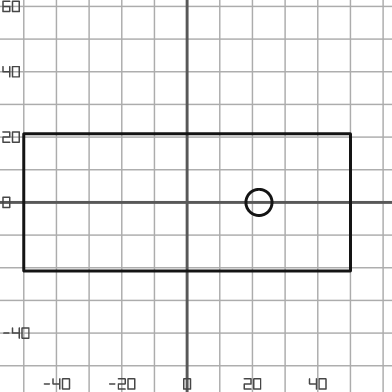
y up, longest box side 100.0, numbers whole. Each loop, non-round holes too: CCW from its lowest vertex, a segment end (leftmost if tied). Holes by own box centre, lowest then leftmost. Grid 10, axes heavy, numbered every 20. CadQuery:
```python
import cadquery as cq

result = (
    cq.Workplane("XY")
    .moveTo(-50.0, -21.0)
    .lineTo(50.0, -21.0)
    .lineTo(50.0, 21.0)
    .lineTo(-50.0, 21.0)
    .close()
    .moveTo(22.0, 0.0)
    .circle(4.0)
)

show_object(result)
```